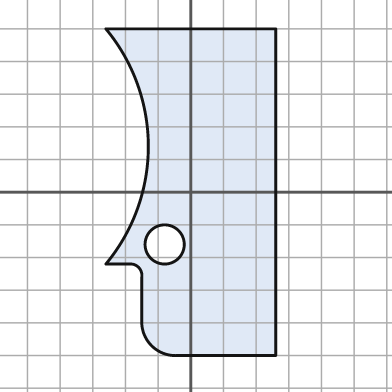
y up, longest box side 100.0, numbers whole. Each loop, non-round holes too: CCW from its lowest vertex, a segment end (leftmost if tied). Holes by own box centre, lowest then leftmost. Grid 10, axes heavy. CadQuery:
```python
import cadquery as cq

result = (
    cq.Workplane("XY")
    .moveTo(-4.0, -50.0)
    .lineTo(26.0, -50.0)
    .lineTo(26.0, 50.0)
    .lineTo(-26.0, 50.0)
    .threePointArc((-13.0, 14.0), (-26.0, -22.0))
    .lineTo(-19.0, -22.0)
    .threePointArc((-16.0, -23.0), (-15.0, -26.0))
    .lineTo(-15.0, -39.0)
    .threePointArc((-12.0, -47.0), (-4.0, -50.0))
    .close()
    .moveTo(-8.0, -16.0)
    .circle(6.0)
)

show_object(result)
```